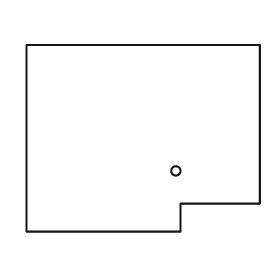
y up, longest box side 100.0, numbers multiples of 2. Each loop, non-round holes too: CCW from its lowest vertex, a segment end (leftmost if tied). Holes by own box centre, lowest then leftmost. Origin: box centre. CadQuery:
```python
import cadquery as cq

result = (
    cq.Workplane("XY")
    .moveTo(-50.0, -40.0)
    .lineTo(16.0, -40.0)
    .lineTo(16.0, -28.0)
    .lineTo(50.0, -28.0)
    .lineTo(50.0, 40.0)
    .lineTo(-50.0, 40.0)
    .close()
    .moveTo(14.0, -14.0)
    .circle(2.0)
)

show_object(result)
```